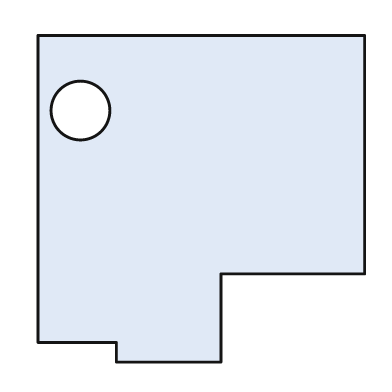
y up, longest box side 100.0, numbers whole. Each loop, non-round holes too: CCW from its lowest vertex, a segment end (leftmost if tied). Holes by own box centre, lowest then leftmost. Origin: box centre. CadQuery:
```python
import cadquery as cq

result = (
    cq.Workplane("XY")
    .moveTo(-26.0, -50.0)
    .lineTo(6.0, -50.0)
    .lineTo(6.0, -23.0)
    .lineTo(50.0, -23.0)
    .lineTo(50.0, 50.0)
    .lineTo(-50.0, 50.0)
    .lineTo(-50.0, -44.0)
    .lineTo(-26.0, -44.0)
    .close()
    .moveTo(-37.0, 27.0)
    .circle(9.0)
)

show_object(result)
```